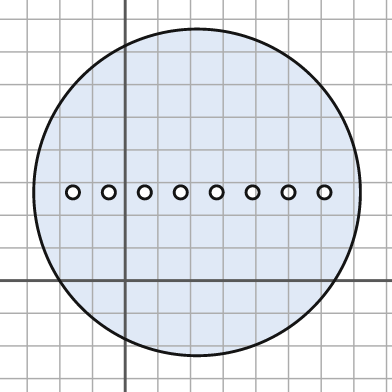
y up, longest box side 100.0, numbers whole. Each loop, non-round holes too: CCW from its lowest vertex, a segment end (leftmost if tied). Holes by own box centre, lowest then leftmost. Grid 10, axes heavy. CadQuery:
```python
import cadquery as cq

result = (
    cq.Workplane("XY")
    .moveTo(22.0, 27.0)
    .circle(50.0)
    .moveTo(-16.0, 27.0)
    .circle(2.0)
    .moveTo(-5.0, 27.0)
    .circle(2.0)
    .moveTo(6.0, 27.0)
    .circle(2.0)
    .moveTo(17.0, 27.0)
    .circle(2.0)
    .moveTo(28.0, 27.0)
    .circle(2.0)
    .moveTo(39.0, 27.0)
    .circle(2.0)
    .moveTo(50.0, 27.0)
    .circle(2.0)
    .moveTo(61.0, 27.0)
    .circle(2.0)
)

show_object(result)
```